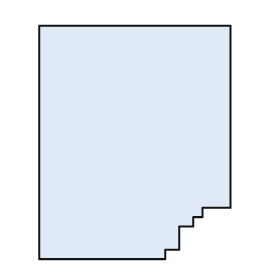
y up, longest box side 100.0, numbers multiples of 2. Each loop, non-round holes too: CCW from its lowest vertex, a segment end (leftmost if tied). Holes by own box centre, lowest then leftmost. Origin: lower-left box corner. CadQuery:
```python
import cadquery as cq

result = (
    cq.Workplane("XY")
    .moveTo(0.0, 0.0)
    .lineTo(54.0, 0.0)
    .lineTo(54.0, 4.0)
    .lineTo(60.0, 4.0)
    .lineTo(60.0, 14.0)
    .lineTo(66.0, 14.0)
    .lineTo(66.0, 18.0)
    .lineTo(70.0, 18.0)
    .lineTo(70.0, 22.0)
    .lineTo(82.0, 22.0)
    .lineTo(82.0, 100.0)
    .lineTo(0.0, 100.0)
    .close()
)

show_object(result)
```